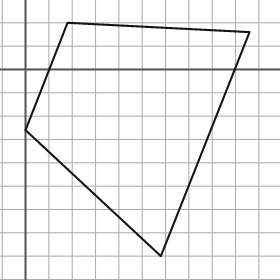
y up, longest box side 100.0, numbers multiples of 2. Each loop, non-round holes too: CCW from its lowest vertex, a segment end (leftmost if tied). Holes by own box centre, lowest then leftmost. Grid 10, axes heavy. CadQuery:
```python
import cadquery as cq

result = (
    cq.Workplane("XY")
    .moveTo(58.0, -80.0)
    .lineTo(96.0, 16.0)
    .lineTo(18.0, 20.0)
    .lineTo(0.0, -26.0)
    .close()
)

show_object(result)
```